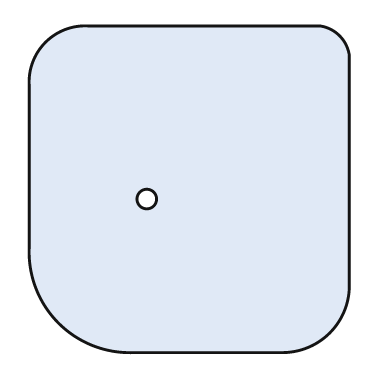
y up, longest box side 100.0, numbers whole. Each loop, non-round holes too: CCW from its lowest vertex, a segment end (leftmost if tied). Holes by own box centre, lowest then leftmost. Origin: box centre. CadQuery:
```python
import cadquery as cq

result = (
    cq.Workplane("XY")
    .moveTo(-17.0, -50.0)
    .lineTo(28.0, -50.0)
    .threePointArc((43.0, -44.0), (49.0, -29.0))
    .lineTo(49.0, 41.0)
    .threePointArc((46.0, 47.0), (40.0, 50.0))
    .lineTo(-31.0, 50.0)
    .threePointArc((-44.0, 45.0), (-49.0, 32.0))
    .lineTo(-49.0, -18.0)
    .threePointArc((-40.0, -41.0), (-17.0, -50.0))
    .close()
    .moveTo(-13.0, -3.0)
    .circle(3.0)
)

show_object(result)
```